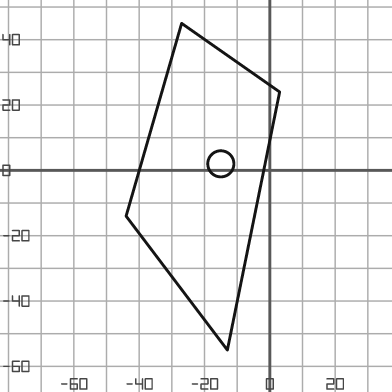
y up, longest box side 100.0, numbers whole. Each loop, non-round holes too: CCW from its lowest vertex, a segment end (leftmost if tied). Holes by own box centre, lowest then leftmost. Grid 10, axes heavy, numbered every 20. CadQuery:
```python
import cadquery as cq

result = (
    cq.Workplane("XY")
    .moveTo(-13.0, -55.0)
    .lineTo(3.0, 24.0)
    .lineTo(-27.0, 45.0)
    .lineTo(-44.0, -14.0)
    .close()
    .moveTo(-15.0, 2.0)
    .circle(4.0)
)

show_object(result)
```